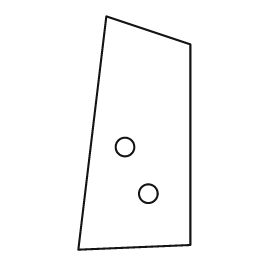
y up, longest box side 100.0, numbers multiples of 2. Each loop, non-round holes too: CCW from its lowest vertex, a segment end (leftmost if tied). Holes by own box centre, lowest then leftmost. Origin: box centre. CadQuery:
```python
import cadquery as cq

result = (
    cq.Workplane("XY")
    .moveTo(-24.0, -50.0)
    .lineTo(24.0, -48.0)
    .lineTo(24.0, 38.0)
    .lineTo(-12.0, 50.0)
    .close()
    .moveTo(6.0, -26.0)
    .circle(4.0)
    .moveTo(-4.0, -6.0)
    .circle(4.0)
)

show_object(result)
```